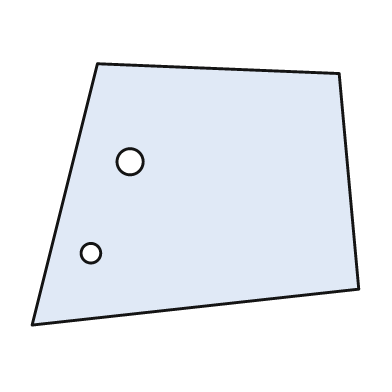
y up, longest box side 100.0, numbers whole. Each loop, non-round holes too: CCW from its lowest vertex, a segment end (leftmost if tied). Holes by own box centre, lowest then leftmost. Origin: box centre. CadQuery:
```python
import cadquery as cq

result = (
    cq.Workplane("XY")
    .moveTo(-50.0, -40.0)
    .lineTo(50.0, -29.0)
    .lineTo(44.0, 37.0)
    .lineTo(-30.0, 40.0)
    .close()
    .moveTo(-32.0, -18.0)
    .circle(3.0)
    .moveTo(-20.0, 10.0)
    .circle(4.0)
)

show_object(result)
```